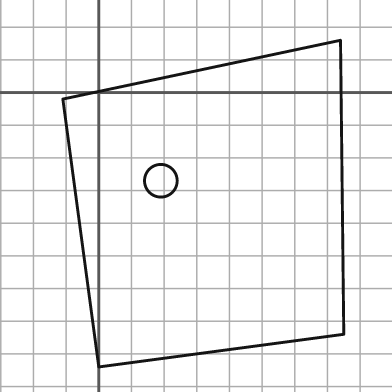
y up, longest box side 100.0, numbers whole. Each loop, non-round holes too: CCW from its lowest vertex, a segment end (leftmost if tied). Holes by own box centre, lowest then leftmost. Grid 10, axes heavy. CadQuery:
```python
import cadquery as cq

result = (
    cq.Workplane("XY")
    .moveTo(0.0, -84.0)
    .lineTo(75.0, -74.0)
    .lineTo(74.0, 16.0)
    .lineTo(-11.0, -2.0)
    .close()
    .moveTo(19.0, -27.0)
    .circle(5.0)
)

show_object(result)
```